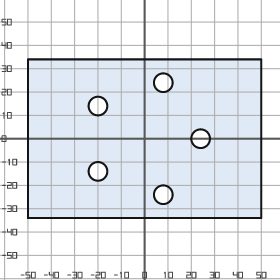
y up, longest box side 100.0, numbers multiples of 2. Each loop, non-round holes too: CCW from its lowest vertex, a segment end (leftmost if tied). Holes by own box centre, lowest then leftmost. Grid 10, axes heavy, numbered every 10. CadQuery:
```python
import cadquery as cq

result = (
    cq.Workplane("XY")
    .moveTo(-50.0, -34.0)
    .lineTo(50.0, -34.0)
    .lineTo(50.0, 34.0)
    .lineTo(-50.0, 34.0)
    .close()
    .moveTo(8.0, -24.0)
    .circle(4.0)
    .moveTo(-20.0, -14.0)
    .circle(4.0)
    .moveTo(24.0, 0.0)
    .circle(4.0)
    .moveTo(-20.0, 14.0)
    .circle(4.0)
    .moveTo(8.0, 24.0)
    .circle(4.0)
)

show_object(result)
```